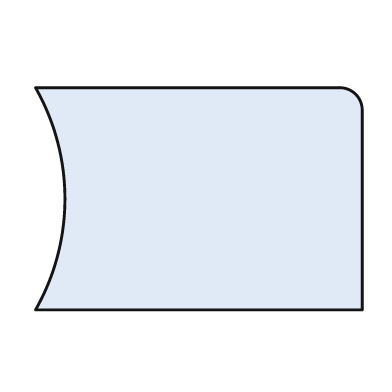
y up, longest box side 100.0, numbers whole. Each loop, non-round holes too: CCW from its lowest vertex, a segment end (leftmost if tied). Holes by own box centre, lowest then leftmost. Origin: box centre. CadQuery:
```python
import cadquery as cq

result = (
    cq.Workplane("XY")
    .moveTo(-50.0, -34.0)
    .lineTo(50.0, -34.0)
    .lineTo(50.0, 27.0)
    .threePointArc((48.0, 32.0), (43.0, 34.0))
    .lineTo(-50.0, 34.0)
    .threePointArc((-41.0, 0.0), (-50.0, -34.0))
    .close()
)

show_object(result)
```